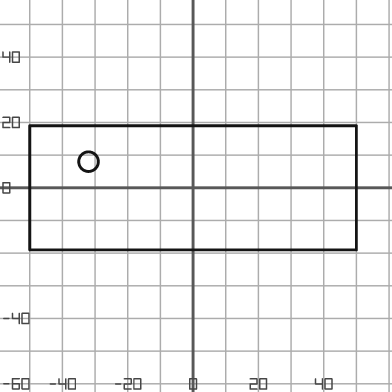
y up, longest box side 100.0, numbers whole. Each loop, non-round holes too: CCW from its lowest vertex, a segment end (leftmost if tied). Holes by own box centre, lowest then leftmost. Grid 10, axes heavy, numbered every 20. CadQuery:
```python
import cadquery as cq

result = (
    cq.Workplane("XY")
    .moveTo(-50.0, -19.0)
    .lineTo(50.0, -19.0)
    .lineTo(50.0, 19.0)
    .lineTo(-50.0, 19.0)
    .close()
    .moveTo(-32.0, 8.0)
    .circle(3.0)
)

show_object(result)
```